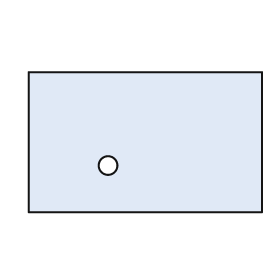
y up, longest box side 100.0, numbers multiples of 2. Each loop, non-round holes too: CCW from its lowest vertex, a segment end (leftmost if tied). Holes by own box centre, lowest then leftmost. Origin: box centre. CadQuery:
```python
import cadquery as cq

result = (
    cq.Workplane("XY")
    .moveTo(-50.0, -30.0)
    .lineTo(50.0, -30.0)
    .lineTo(50.0, 30.0)
    .lineTo(-50.0, 30.0)
    .close()
    .moveTo(-16.0, -10.0)
    .circle(4.0)
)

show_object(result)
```